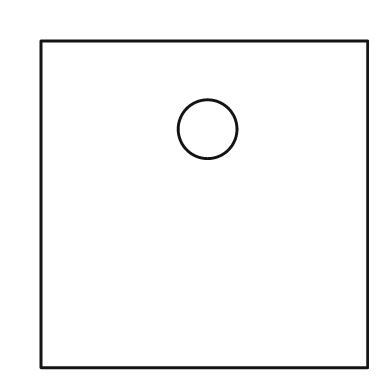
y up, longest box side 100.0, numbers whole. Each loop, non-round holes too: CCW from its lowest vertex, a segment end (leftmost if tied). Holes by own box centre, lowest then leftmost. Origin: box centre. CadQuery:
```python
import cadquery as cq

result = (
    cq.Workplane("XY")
    .moveTo(-50.0, -50.0)
    .lineTo(50.0, -50.0)
    .lineTo(50.0, 50.0)
    .lineTo(-50.0, 50.0)
    .close()
    .moveTo(1.0, 23.0)
    .circle(9.0)
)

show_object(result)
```